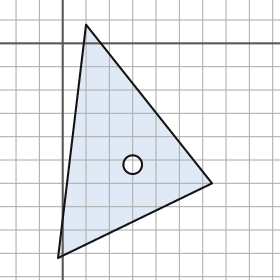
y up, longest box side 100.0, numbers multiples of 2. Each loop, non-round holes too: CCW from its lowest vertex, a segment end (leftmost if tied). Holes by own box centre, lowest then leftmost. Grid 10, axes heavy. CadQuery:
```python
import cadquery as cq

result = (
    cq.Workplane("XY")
    .moveTo(-2.0, -92.0)
    .lineTo(64.0, -60.0)
    .lineTo(10.0, 8.0)
    .close()
    .moveTo(30.0, -52.0)
    .circle(4.0)
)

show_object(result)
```